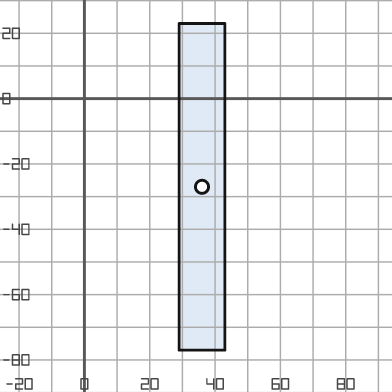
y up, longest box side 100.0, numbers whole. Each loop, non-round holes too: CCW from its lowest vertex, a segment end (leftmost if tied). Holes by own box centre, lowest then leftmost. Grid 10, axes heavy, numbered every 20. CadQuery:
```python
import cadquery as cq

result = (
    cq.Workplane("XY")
    .moveTo(29.0, -77.0)
    .lineTo(43.0, -77.0)
    .lineTo(43.0, 23.0)
    .lineTo(29.0, 23.0)
    .close()
    .moveTo(36.0, -27.0)
    .circle(2.0)
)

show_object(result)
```